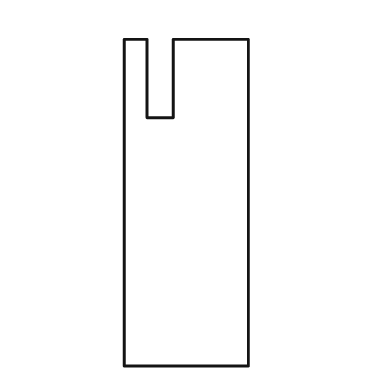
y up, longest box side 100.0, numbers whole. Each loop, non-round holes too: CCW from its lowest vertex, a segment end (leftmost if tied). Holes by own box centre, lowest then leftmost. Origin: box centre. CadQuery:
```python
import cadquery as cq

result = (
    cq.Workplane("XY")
    .moveTo(-19.0, -50.0)
    .lineTo(19.0, -50.0)
    .lineTo(19.0, 50.0)
    .lineTo(-4.0, 50.0)
    .lineTo(-4.0, 26.0)
    .lineTo(-12.0, 26.0)
    .lineTo(-12.0, 50.0)
    .lineTo(-19.0, 50.0)
    .close()
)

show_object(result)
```